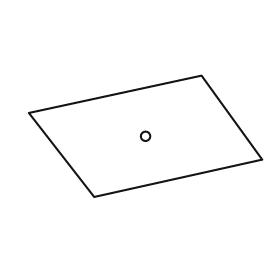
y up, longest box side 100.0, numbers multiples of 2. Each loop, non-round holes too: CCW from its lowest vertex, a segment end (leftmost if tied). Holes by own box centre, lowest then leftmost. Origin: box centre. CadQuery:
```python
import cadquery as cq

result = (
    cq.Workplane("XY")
    .moveTo(-22.0, -26.0)
    .lineTo(50.0, -10.0)
    .lineTo(24.0, 26.0)
    .lineTo(-50.0, 10.0)
    .close()
    .moveTo(0.0, 0.0)
    .circle(2.0)
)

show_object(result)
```